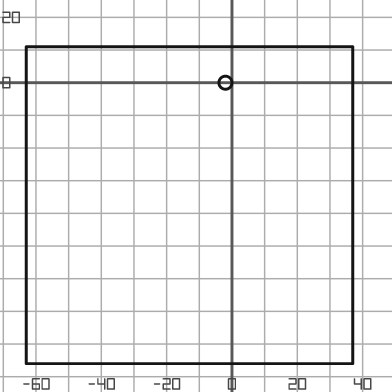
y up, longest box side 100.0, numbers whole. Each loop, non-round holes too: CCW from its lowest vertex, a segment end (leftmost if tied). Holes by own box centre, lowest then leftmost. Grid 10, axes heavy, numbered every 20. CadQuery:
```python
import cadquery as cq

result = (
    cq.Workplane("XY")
    .moveTo(-63.0, -86.0)
    .lineTo(37.0, -86.0)
    .lineTo(37.0, 11.0)
    .lineTo(-63.0, 11.0)
    .close()
    .moveTo(-2.0, 0.0)
    .circle(2.0)
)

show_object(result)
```